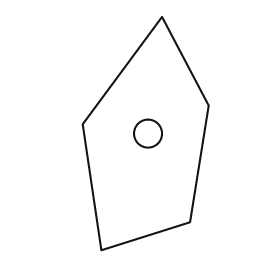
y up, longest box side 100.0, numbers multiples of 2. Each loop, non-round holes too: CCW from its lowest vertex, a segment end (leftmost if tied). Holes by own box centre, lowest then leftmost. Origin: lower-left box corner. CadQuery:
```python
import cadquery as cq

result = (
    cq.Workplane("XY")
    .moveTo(8.0, 0.0)
    .lineTo(46.0, 12.0)
    .lineTo(54.0, 62.0)
    .lineTo(34.0, 100.0)
    .lineTo(0.0, 54.0)
    .close()
    .moveTo(28.0, 50.0)
    .circle(6.0)
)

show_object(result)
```